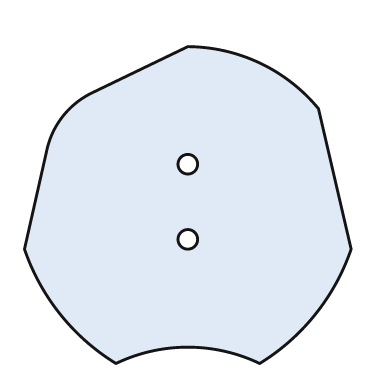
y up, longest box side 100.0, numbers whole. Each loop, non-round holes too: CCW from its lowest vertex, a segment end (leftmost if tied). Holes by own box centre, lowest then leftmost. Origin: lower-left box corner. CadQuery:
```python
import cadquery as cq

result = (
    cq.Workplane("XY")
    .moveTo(28.0, 0.0)
    .threePointArc((50.0, 5.0), (72.0, 0.0))
    .threePointArc((89.0, 15.0), (100.0, 35.0))
    .lineTo(90.0, 78.0)
    .threePointArc((72.0, 92.0), (50.0, 97.0))
    .lineTo(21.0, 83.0)
    .threePointArc((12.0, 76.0), (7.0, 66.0))
    .lineTo(0.0, 35.0)
    .threePointArc((11.0, 15.0), (28.0, 0.0))
    .close()
    .moveTo(50.0, 38.0)
    .circle(3.0)
    .moveTo(50.0, 61.0)
    .circle(3.0)
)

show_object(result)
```